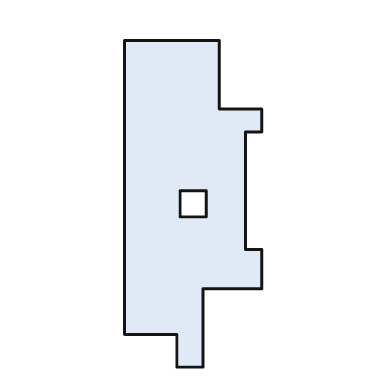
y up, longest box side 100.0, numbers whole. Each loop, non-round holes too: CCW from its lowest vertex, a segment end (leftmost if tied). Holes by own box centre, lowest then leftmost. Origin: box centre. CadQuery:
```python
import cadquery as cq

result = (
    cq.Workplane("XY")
    .moveTo(-5.0, -50.0)
    .lineTo(3.0, -50.0)
    .lineTo(3.0, -26.0)
    .lineTo(21.0, -26.0)
    .lineTo(21.0, -14.0)
    .lineTo(16.0, -14.0)
    .lineTo(16.0, 22.0)
    .lineTo(21.0, 22.0)
    .lineTo(21.0, 29.0)
    .lineTo(8.0, 29.0)
    .lineTo(8.0, 50.0)
    .lineTo(-21.0, 50.0)
    .lineTo(-21.0, -40.0)
    .lineTo(-5.0, -40.0)
    .close()
    .moveTo(-4.0, -4.0)
    .lineTo(4.0, -4.0)
    .lineTo(4.0, 4.0)
    .lineTo(-4.0, 4.0)
    .close()
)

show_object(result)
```